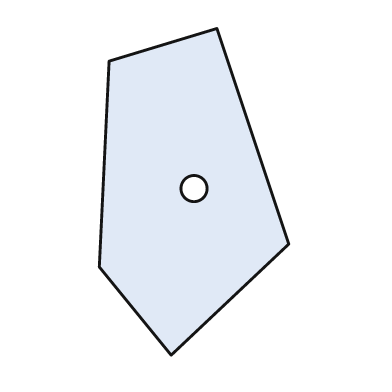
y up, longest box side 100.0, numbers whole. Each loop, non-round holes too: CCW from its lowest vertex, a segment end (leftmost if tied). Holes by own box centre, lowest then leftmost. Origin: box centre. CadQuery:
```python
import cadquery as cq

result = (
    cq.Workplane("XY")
    .moveTo(-7.0, -50.0)
    .lineTo(29.0, -16.0)
    .lineTo(7.0, 50.0)
    .lineTo(-26.0, 40.0)
    .lineTo(-29.0, -23.0)
    .close()
    .moveTo(0.0, 1.0)
    .circle(4.0)
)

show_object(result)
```